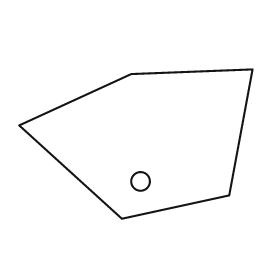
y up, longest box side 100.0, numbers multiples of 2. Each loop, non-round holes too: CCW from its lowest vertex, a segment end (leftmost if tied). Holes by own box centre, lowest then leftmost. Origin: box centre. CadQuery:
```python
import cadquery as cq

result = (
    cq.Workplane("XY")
    .moveTo(-6.0, -32.0)
    .lineTo(40.0, -22.0)
    .lineTo(50.0, 32.0)
    .lineTo(-2.0, 30.0)
    .lineTo(-50.0, 8.0)
    .close()
    .moveTo(2.0, -16.0)
    .circle(4.0)
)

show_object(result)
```